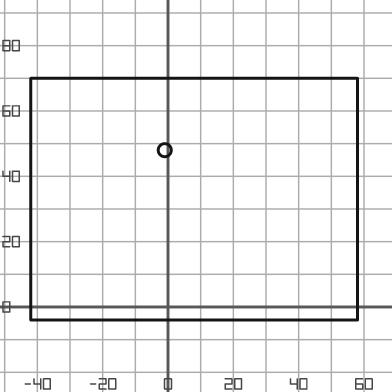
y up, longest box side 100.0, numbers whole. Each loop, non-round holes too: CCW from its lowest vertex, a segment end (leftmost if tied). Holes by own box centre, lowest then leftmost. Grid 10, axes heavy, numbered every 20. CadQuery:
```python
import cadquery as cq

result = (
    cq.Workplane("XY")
    .moveTo(-42.0, -4.0)
    .lineTo(58.0, -4.0)
    .lineTo(58.0, 70.0)
    .lineTo(-42.0, 70.0)
    .close()
    .moveTo(-1.0, 48.0)
    .circle(2.0)
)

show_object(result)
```